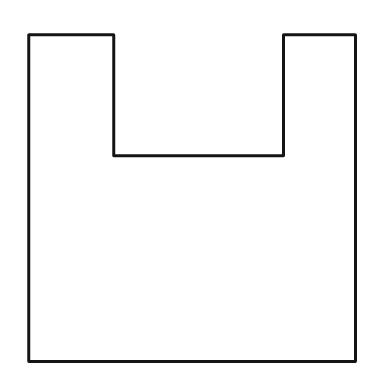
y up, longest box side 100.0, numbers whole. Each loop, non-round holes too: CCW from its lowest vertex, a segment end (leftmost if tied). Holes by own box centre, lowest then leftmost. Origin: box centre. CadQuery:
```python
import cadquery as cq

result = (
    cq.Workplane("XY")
    .moveTo(-50.0, -50.0)
    .lineTo(50.0, -50.0)
    .lineTo(50.0, 50.0)
    .lineTo(28.0, 50.0)
    .lineTo(28.0, 13.0)
    .lineTo(-24.0, 13.0)
    .lineTo(-24.0, 50.0)
    .lineTo(-50.0, 50.0)
    .close()
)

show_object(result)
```